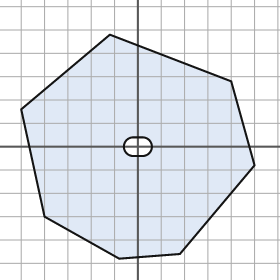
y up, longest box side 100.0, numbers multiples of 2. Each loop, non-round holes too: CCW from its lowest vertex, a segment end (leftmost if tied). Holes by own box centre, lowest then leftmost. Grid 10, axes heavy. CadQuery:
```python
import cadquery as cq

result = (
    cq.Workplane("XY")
    .moveTo(-8.0, -48.0)
    .lineTo(18.0, -46.0)
    .lineTo(50.0, -8.0)
    .lineTo(40.0, 28.0)
    .lineTo(-12.0, 48.0)
    .lineTo(-50.0, 16.0)
    .lineTo(-40.0, -30.0)
    .close()
    .moveTo(-2.0, -4.0)
    .lineTo(2.0, -4.0)
    .threePointArc((6.0, 0.0), (2.0, 4.0))
    .lineTo(-2.0, 4.0)
    .threePointArc((-6.0, 0.0), (-2.0, -4.0))
    .close()
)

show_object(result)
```